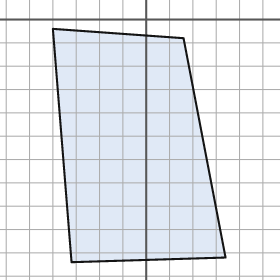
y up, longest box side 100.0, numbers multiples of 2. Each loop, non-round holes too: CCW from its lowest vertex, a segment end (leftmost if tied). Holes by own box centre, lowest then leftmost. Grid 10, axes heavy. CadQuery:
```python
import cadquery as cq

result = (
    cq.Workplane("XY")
    .moveTo(-32.0, -104.0)
    .lineTo(34.0, -102.0)
    .lineTo(16.0, -8.0)
    .lineTo(-40.0, -4.0)
    .close()
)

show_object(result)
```